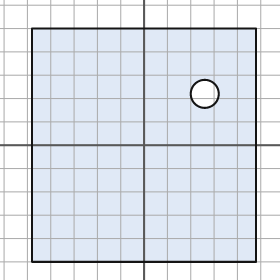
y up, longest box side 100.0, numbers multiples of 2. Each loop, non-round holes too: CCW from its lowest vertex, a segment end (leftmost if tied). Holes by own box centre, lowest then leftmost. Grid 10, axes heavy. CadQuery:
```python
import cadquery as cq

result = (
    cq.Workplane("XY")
    .moveTo(-48.0, -50.0)
    .lineTo(48.0, -50.0)
    .lineTo(48.0, 50.0)
    .lineTo(-48.0, 50.0)
    .close()
    .moveTo(26.0, 22.0)
    .circle(6.0)
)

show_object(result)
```